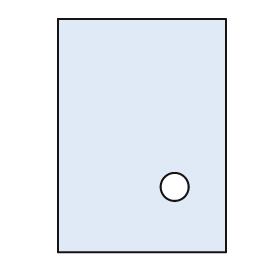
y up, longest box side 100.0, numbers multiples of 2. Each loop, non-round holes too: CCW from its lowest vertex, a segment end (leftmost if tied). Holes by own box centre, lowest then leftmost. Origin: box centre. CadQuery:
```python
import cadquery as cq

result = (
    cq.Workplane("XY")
    .moveTo(-36.0, -50.0)
    .lineTo(36.0, -50.0)
    .lineTo(36.0, 50.0)
    .lineTo(-36.0, 50.0)
    .close()
    .moveTo(14.0, -22.0)
    .circle(6.0)
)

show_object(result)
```